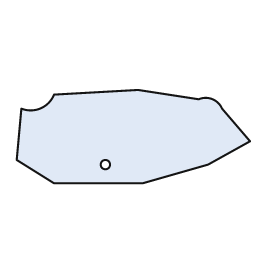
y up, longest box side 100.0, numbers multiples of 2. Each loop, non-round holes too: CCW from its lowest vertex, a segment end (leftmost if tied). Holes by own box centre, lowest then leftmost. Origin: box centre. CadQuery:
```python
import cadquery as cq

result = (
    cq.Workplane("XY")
    .moveTo(-34.0, -20.0)
    .lineTo(4.0, -20.0)
    .lineTo(32.0, -12.0)
    .lineTo(50.0, -2.0)
    .lineTo(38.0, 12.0)
    .threePointArc((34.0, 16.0), (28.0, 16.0))
    .lineTo(2.0, 20.0)
    .lineTo(-34.0, 18.0)
    .threePointArc((-40.0, 12.0), (-48.0, 12.0))
    .lineTo(-50.0, -10.0)
    .close()
    .moveTo(-12.0, -12.0)
    .circle(2.0)
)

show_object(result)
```